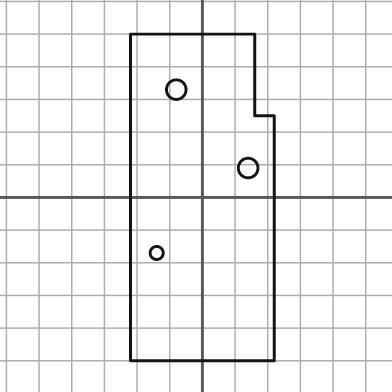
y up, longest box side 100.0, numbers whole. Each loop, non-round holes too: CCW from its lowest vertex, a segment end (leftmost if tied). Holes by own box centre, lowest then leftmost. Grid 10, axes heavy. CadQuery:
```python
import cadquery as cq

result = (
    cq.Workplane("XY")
    .moveTo(-22.0, -50.0)
    .lineTo(22.0, -50.0)
    .lineTo(22.0, 25.0)
    .lineTo(16.0, 25.0)
    .lineTo(16.0, 50.0)
    .lineTo(-22.0, 50.0)
    .close()
    .moveTo(-14.0, -17.0)
    .circle(2.0)
    .moveTo(14.0, 9.0)
    .circle(3.0)
    .moveTo(-8.0, 33.0)
    .circle(3.0)
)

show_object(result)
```